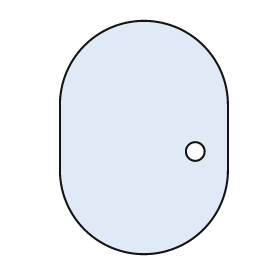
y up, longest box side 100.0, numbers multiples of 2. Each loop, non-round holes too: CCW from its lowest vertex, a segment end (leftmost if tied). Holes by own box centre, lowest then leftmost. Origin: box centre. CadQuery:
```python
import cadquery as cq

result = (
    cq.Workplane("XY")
    .moveTo(-36.0, -14.0)
    .threePointArc((0.0, -50.0), (36.0, -14.0))
    .lineTo(36.0, 14.0)
    .threePointArc((0.0, 50.0), (-36.0, 14.0))
    .close()
    .moveTo(22.0, -6.0)
    .circle(4.0)
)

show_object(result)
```